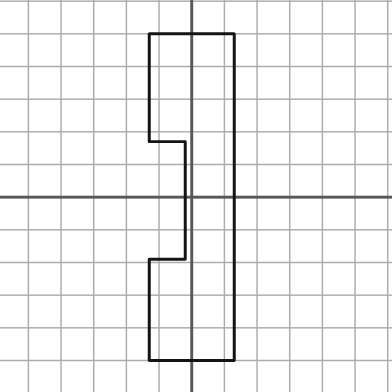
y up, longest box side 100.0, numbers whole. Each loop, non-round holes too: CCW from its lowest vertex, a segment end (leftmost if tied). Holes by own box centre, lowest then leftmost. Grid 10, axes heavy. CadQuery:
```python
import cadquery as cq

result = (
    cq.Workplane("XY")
    .moveTo(-13.0, -50.0)
    .lineTo(13.0, -50.0)
    .lineTo(13.0, 50.0)
    .lineTo(-13.0, 50.0)
    .lineTo(-13.0, 17.0)
    .lineTo(-2.0, 17.0)
    .lineTo(-2.0, -19.0)
    .lineTo(-13.0, -19.0)
    .close()
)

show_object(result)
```